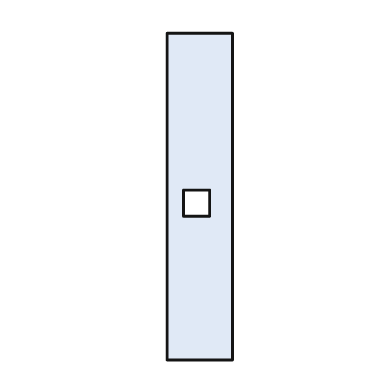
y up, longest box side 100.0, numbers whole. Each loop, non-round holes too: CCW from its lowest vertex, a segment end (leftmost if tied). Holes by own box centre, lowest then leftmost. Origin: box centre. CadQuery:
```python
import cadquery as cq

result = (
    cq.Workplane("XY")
    .moveTo(-10.0, -50.0)
    .lineTo(10.0, -50.0)
    .lineTo(10.0, 50.0)
    .lineTo(-10.0, 50.0)
    .close()
    .moveTo(-5.0, -6.0)
    .lineTo(3.0, -6.0)
    .lineTo(3.0, 2.0)
    .lineTo(-5.0, 2.0)
    .close()
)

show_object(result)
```